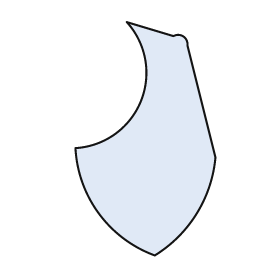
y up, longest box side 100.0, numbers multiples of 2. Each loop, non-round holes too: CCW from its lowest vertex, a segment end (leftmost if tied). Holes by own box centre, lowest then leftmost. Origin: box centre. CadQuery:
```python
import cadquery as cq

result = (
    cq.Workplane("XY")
    .moveTo(4.0, -50.0)
    .threePointArc((22.0, -32.0), (30.0, -8.0))
    .lineTo(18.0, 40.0)
    .threePointArc((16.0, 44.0), (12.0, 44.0))
    .lineTo(-8.0, 50.0)
    .threePointArc((-2.0, 16.0), (-30.0, -4.0))
    .threePointArc((-20.0, -32.0), (4.0, -50.0))
    .close()
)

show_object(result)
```